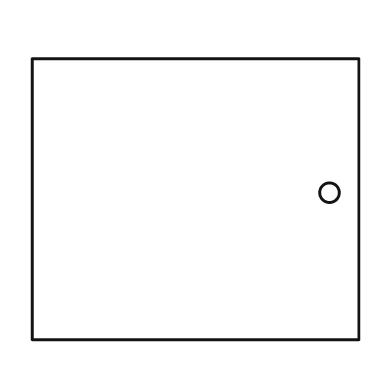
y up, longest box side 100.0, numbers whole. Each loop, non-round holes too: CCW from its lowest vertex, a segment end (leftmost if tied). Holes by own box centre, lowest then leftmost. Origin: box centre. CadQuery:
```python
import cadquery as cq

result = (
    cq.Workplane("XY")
    .moveTo(-50.0, -43.0)
    .lineTo(50.0, -43.0)
    .lineTo(50.0, 43.0)
    .lineTo(-50.0, 43.0)
    .close()
    .moveTo(41.0, 2.0)
    .circle(3.0)
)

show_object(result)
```